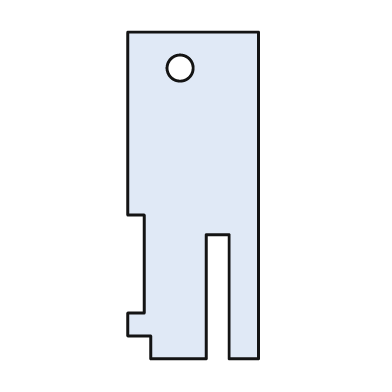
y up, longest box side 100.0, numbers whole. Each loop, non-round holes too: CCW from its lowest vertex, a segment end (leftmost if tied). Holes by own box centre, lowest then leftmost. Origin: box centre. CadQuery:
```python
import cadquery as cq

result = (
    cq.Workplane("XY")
    .moveTo(-13.0, -50.0)
    .lineTo(4.0, -50.0)
    .lineTo(4.0, -12.0)
    .lineTo(11.0, -12.0)
    .lineTo(11.0, -50.0)
    .lineTo(20.0, -50.0)
    .lineTo(20.0, 50.0)
    .lineTo(-20.0, 50.0)
    .lineTo(-20.0, -6.0)
    .lineTo(-15.0, -6.0)
    .lineTo(-15.0, -36.0)
    .lineTo(-20.0, -36.0)
    .lineTo(-20.0, -43.0)
    .lineTo(-13.0, -43.0)
    .close()
    .moveTo(-4.0, 39.0)
    .circle(4.0)
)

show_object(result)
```